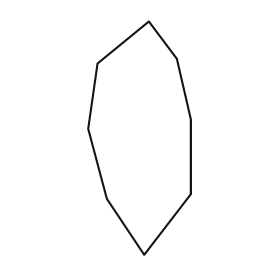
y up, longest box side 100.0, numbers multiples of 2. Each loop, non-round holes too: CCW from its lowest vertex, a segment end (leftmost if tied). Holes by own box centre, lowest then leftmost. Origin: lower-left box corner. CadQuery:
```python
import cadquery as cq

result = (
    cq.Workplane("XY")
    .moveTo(24.0, 0.0)
    .lineTo(44.0, 26.0)
    .lineTo(44.0, 58.0)
    .lineTo(38.0, 84.0)
    .lineTo(26.0, 100.0)
    .lineTo(4.0, 82.0)
    .lineTo(0.0, 54.0)
    .lineTo(8.0, 24.0)
    .close()
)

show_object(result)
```